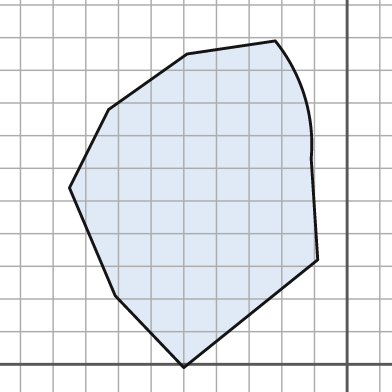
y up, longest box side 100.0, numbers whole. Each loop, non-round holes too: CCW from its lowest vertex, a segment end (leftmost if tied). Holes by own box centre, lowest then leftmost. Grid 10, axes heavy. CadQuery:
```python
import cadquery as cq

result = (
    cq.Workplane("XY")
    .moveTo(-50.0, -1.0)
    .lineTo(-9.0, 32.0)
    .lineTo(-11.0, 63.0)
    .threePointArc((-13.0, 82.0), (-22.0, 99.0))
    .lineTo(-49.0, 95.0)
    .lineTo(-73.0, 78.0)
    .lineTo(-85.0, 54.0)
    .lineTo(-71.0, 21.0)
    .close()
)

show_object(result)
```